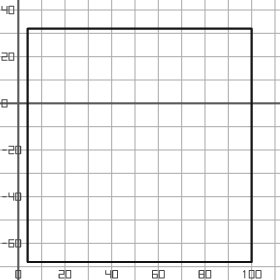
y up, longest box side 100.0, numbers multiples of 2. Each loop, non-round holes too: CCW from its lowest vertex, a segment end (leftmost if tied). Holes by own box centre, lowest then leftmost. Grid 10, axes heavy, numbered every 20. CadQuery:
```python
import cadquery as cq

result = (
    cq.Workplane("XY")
    .moveTo(4.0, -68.0)
    .lineTo(100.0, -68.0)
    .lineTo(100.0, 32.0)
    .lineTo(4.0, 32.0)
    .close()
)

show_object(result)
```